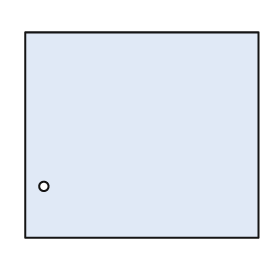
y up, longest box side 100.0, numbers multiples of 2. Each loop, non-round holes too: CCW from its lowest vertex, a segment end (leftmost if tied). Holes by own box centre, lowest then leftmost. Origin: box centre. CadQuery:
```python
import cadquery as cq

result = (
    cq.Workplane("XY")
    .moveTo(-50.0, -44.0)
    .lineTo(50.0, -44.0)
    .lineTo(50.0, 44.0)
    .lineTo(-50.0, 44.0)
    .close()
    .moveTo(-42.0, -22.0)
    .circle(2.0)
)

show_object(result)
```